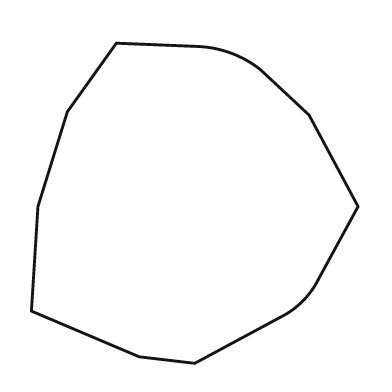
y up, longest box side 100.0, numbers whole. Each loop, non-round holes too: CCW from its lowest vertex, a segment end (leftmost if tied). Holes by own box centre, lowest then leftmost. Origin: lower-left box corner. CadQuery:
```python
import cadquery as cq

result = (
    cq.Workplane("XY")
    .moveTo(50.0, 0.0)
    .lineTo(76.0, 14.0)
    .threePointArc((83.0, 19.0), (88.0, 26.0))
    .lineTo(100.0, 48.0)
    .lineTo(85.0, 76.0)
    .lineTo(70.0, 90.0)
    .threePointArc((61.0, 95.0), (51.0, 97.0))
    .lineTo(26.0, 98.0)
    .lineTo(11.0, 77.0)
    .lineTo(2.0, 48.0)
    .lineTo(0.0, 16.0)
    .lineTo(33.0, 2.0)
    .close()
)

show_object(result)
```